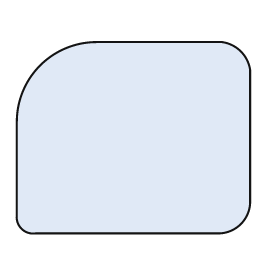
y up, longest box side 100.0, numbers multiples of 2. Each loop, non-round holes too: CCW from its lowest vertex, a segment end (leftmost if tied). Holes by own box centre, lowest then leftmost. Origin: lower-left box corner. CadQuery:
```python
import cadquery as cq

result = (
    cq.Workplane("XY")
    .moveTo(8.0, 0.0)
    .lineTo(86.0, 0.0)
    .threePointArc((96.0, 4.0), (100.0, 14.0))
    .lineTo(100.0, 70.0)
    .threePointArc((96.0, 78.0), (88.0, 82.0))
    .lineTo(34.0, 82.0)
    .threePointArc((10.0, 72.0), (0.0, 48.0))
    .lineTo(0.0, 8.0)
    .threePointArc((2.0, 2.0), (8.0, 0.0))
    .close()
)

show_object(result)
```